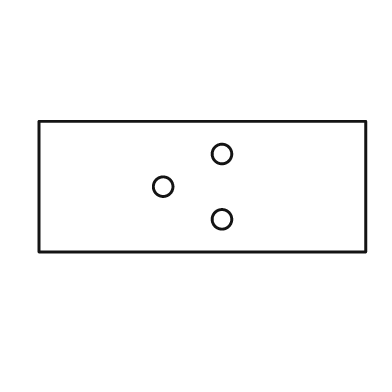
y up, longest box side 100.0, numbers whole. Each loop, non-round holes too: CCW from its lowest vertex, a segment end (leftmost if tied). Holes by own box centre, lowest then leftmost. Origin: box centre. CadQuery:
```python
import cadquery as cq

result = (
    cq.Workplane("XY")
    .moveTo(-50.0, -20.0)
    .lineTo(50.0, -20.0)
    .lineTo(50.0, 20.0)
    .lineTo(-50.0, 20.0)
    .close()
    .moveTo(6.0, -10.0)
    .circle(3.0)
    .moveTo(-12.0, 0.0)
    .circle(3.0)
    .moveTo(6.0, 10.0)
    .circle(3.0)
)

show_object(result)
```